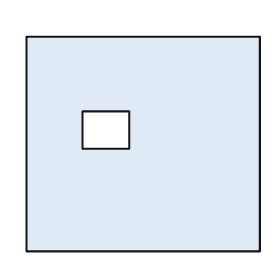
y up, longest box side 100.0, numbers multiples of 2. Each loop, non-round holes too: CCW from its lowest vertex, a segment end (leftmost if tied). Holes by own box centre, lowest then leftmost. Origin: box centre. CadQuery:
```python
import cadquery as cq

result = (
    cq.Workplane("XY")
    .moveTo(-50.0, -46.0)
    .lineTo(50.0, -46.0)
    .lineTo(50.0, 46.0)
    .lineTo(-50.0, 46.0)
    .close()
    .moveTo(-26.0, -2.0)
    .lineTo(-6.0, -2.0)
    .lineTo(-6.0, 14.0)
    .lineTo(-26.0, 14.0)
    .close()
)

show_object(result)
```